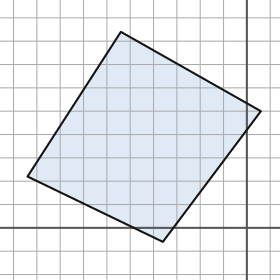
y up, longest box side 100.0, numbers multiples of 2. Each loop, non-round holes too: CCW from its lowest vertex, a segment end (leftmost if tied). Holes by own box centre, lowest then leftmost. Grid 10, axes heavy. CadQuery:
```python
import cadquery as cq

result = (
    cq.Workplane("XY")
    .moveTo(-36.0, -6.0)
    .lineTo(6.0, 50.0)
    .lineTo(-54.0, 84.0)
    .lineTo(-94.0, 22.0)
    .close()
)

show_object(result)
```